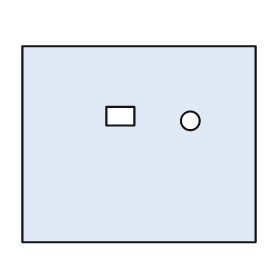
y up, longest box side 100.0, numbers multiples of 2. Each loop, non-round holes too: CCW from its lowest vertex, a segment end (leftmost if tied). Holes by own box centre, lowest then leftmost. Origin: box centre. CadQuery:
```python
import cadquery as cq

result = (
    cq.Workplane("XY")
    .moveTo(-50.0, -42.0)
    .lineTo(50.0, -42.0)
    .lineTo(50.0, 42.0)
    .lineTo(-50.0, 42.0)
    .close()
    .moveTo(22.0, 10.0)
    .circle(4.0)
    .moveTo(-14.0, 8.0)
    .lineTo(-2.0, 8.0)
    .lineTo(-2.0, 16.0)
    .lineTo(-14.0, 16.0)
    .close()
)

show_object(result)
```